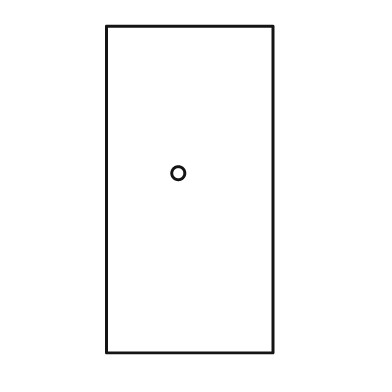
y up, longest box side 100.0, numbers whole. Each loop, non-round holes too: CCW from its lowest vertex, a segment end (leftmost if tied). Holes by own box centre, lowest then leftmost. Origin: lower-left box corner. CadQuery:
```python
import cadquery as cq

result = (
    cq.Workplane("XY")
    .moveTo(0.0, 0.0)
    .lineTo(51.0, 0.0)
    .lineTo(51.0, 100.0)
    .lineTo(0.0, 100.0)
    .close()
    .moveTo(22.0, 55.0)
    .circle(2.0)
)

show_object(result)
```